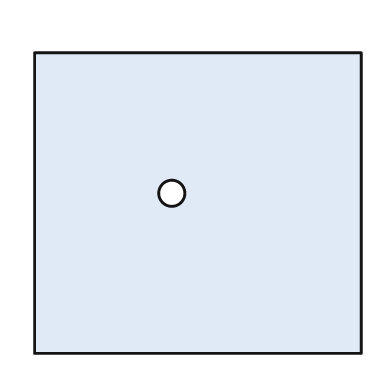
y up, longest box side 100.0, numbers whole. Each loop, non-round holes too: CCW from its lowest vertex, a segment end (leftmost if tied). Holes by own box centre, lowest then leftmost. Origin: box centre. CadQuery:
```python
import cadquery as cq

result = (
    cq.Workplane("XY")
    .moveTo(-50.0, -46.0)
    .lineTo(50.0, -46.0)
    .lineTo(50.0, 46.0)
    .lineTo(-50.0, 46.0)
    .close()
    .moveTo(-8.0, 3.0)
    .circle(4.0)
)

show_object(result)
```